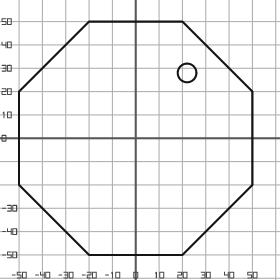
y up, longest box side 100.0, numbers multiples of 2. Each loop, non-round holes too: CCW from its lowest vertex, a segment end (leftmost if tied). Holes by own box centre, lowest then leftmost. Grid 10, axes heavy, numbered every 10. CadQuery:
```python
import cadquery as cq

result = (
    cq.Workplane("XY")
    .moveTo(-20.0, -50.0)
    .lineTo(20.0, -50.0)
    .lineTo(50.0, -20.0)
    .lineTo(50.0, 20.0)
    .lineTo(20.0, 50.0)
    .lineTo(-20.0, 50.0)
    .lineTo(-50.0, 20.0)
    .lineTo(-50.0, -20.0)
    .close()
    .moveTo(22.0, 28.0)
    .circle(4.0)
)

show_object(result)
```